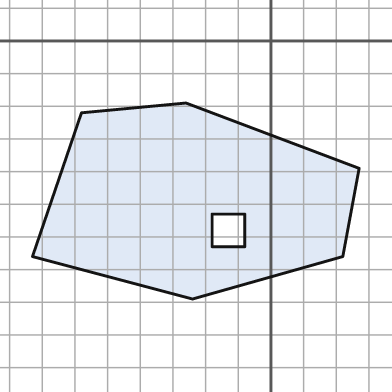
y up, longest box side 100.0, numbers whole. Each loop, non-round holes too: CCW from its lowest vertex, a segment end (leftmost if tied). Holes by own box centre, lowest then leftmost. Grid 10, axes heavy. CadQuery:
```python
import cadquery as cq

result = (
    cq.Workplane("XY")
    .moveTo(-24.0, -79.0)
    .lineTo(22.0, -66.0)
    .lineTo(27.0, -39.0)
    .lineTo(-26.0, -19.0)
    .lineTo(-58.0, -22.0)
    .lineTo(-73.0, -66.0)
    .close()
    .moveTo(-18.0, -63.0)
    .lineTo(-8.0, -63.0)
    .lineTo(-8.0, -53.0)
    .lineTo(-18.0, -53.0)
    .close()
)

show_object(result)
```